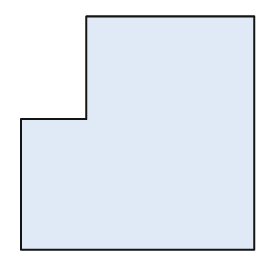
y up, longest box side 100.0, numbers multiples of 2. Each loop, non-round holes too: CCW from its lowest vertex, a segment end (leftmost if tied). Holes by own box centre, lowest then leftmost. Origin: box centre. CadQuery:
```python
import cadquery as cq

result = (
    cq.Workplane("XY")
    .moveTo(-50.0, -50.0)
    .lineTo(50.0, -50.0)
    .lineTo(50.0, 50.0)
    .lineTo(-22.0, 50.0)
    .lineTo(-22.0, 6.0)
    .lineTo(-50.0, 6.0)
    .close()
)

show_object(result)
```